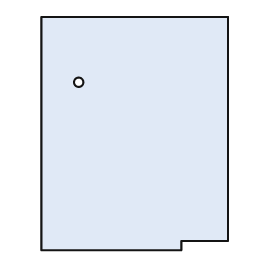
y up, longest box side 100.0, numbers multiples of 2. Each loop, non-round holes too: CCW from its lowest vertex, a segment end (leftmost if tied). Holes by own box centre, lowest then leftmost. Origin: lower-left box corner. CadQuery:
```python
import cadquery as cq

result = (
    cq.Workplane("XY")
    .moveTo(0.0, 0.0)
    .lineTo(60.0, 0.0)
    .lineTo(60.0, 4.0)
    .lineTo(80.0, 4.0)
    .lineTo(80.0, 100.0)
    .lineTo(0.0, 100.0)
    .close()
    .moveTo(16.0, 72.0)
    .circle(2.0)
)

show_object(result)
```